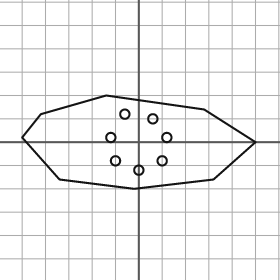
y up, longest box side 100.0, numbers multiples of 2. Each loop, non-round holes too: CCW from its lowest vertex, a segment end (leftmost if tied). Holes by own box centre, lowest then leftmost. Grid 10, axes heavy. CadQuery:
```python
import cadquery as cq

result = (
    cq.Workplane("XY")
    .moveTo(-2.0, -20.0)
    .lineTo(32.0, -16.0)
    .lineTo(50.0, 0.0)
    .lineTo(28.0, 14.0)
    .lineTo(-14.0, 20.0)
    .lineTo(-42.0, 12.0)
    .lineTo(-50.0, 2.0)
    .lineTo(-34.0, -16.0)
    .close()
    .moveTo(0.0, -12.0)
    .circle(2.0)
    .moveTo(-10.0, -8.0)
    .circle(2.0)
    .moveTo(10.0, -8.0)
    .circle(2.0)
    .moveTo(-12.0, 2.0)
    .circle(2.0)
    .moveTo(12.0, 2.0)
    .circle(2.0)
    .moveTo(6.0, 10.0)
    .circle(2.0)
    .moveTo(-6.0, 12.0)
    .circle(2.0)
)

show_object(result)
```